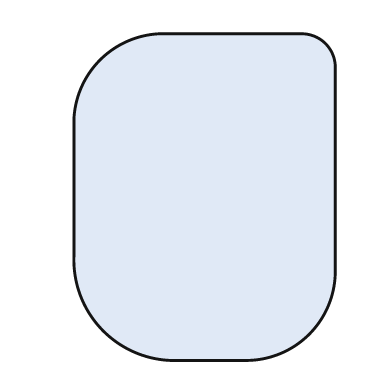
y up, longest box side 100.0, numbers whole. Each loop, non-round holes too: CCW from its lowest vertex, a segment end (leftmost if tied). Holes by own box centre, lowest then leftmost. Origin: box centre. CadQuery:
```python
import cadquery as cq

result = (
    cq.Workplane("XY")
    .moveTo(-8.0, -50.0)
    .lineTo(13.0, -50.0)
    .threePointArc((32.0, -42.0), (40.0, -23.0))
    .lineTo(40.0, 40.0)
    .threePointArc((37.0, 47.0), (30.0, 50.0))
    .lineTo(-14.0, 50.0)
    .threePointArc((-32.0, 42.0), (-40.0, 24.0))
    .lineTo(-40.0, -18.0)
    .threePointArc((-31.0, -41.0), (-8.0, -50.0))
    .close()
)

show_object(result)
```